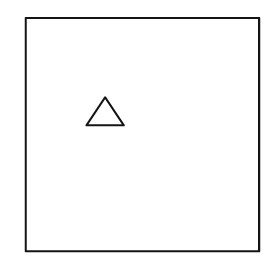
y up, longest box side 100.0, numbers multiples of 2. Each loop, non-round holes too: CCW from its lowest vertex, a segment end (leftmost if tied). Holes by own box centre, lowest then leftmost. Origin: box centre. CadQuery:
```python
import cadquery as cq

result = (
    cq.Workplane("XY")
    .moveTo(-50.0, -50.0)
    .lineTo(50.0, -50.0)
    .lineTo(50.0, 50.0)
    .lineTo(-50.0, 50.0)
    .close()
    .moveTo(-24.0, 4.0)
    .lineTo(-8.0, 4.0)
    .lineTo(-16.0, 16.0)
    .close()
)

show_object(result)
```